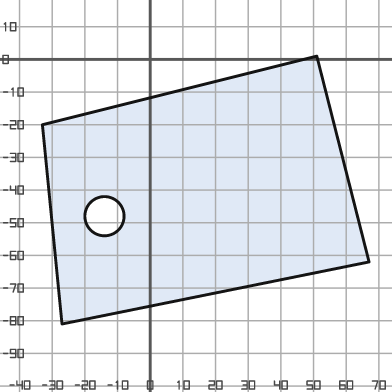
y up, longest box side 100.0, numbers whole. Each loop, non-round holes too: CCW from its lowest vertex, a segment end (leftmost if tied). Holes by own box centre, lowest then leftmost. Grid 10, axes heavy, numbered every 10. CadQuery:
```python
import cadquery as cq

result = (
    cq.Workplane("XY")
    .moveTo(-27.0, -81.0)
    .lineTo(67.0, -62.0)
    .lineTo(51.0, 1.0)
    .lineTo(-33.0, -20.0)
    .close()
    .moveTo(-14.0, -48.0)
    .circle(6.0)
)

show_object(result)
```